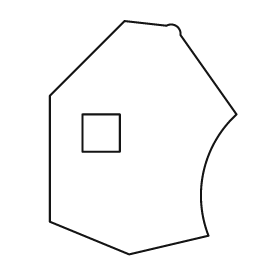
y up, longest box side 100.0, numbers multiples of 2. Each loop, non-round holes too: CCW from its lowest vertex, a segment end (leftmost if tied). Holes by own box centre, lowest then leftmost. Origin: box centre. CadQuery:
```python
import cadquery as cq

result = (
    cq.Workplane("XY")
    .moveTo(-6.0, -50.0)
    .lineTo(28.0, -42.0)
    .threePointArc((26.0, -14.0), (40.0, 10.0))
    .lineTo(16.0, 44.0)
    .threePointArc((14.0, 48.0), (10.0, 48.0))
    .lineTo(-8.0, 50.0)
    .lineTo(-40.0, 18.0)
    .lineTo(-40.0, -36.0)
    .close()
    .moveTo(-26.0, -6.0)
    .lineTo(-10.0, -6.0)
    .lineTo(-10.0, 10.0)
    .lineTo(-26.0, 10.0)
    .close()
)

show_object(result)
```